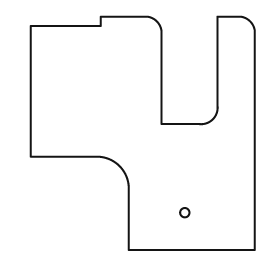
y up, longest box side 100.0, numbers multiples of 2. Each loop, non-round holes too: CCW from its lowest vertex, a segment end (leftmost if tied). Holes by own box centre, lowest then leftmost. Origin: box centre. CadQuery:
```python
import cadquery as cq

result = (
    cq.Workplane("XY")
    .moveTo(-6.0, -50.0)
    .lineTo(48.0, -50.0)
    .lineTo(48.0, 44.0)
    .threePointArc((46.0, 48.0), (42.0, 50.0))
    .lineTo(32.0, 50.0)
    .lineTo(32.0, 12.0)
    .threePointArc((30.0, 6.0), (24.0, 4.0))
    .lineTo(8.0, 4.0)
    .lineTo(8.0, 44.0)
    .threePointArc((6.0, 48.0), (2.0, 50.0))
    .lineTo(-18.0, 50.0)
    .lineTo(-18.0, 46.0)
    .lineTo(-48.0, 46.0)
    .lineTo(-48.0, -10.0)
    .lineTo(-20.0, -10.0)
    .threePointArc((-10.0, -14.0), (-6.0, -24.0))
    .close()
    .moveTo(18.0, -34.0)
    .circle(2.0)
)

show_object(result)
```